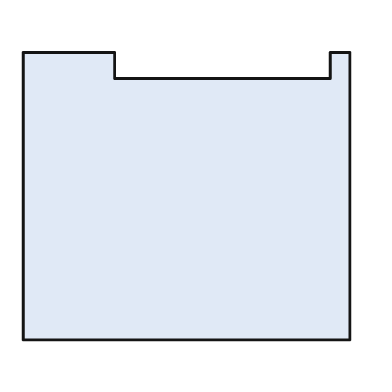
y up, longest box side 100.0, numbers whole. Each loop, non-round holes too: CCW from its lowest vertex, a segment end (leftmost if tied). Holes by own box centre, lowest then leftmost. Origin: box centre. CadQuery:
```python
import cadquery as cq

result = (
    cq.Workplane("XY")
    .moveTo(-50.0, -44.0)
    .lineTo(50.0, -44.0)
    .lineTo(50.0, 44.0)
    .lineTo(44.0, 44.0)
    .lineTo(44.0, 36.0)
    .lineTo(-22.0, 36.0)
    .lineTo(-22.0, 44.0)
    .lineTo(-50.0, 44.0)
    .close()
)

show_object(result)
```